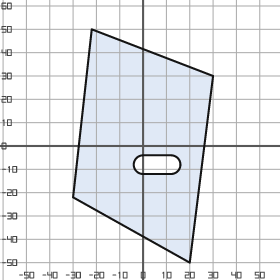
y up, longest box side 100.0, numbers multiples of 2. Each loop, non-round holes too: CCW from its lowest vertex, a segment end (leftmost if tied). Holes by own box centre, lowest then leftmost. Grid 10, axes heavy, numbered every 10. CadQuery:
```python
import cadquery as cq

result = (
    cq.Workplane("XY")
    .moveTo(20.0, -50.0)
    .lineTo(30.0, 30.0)
    .lineTo(-22.0, 50.0)
    .lineTo(-30.0, -22.0)
    .close()
    .moveTo(0.0, -12.0)
    .lineTo(12.0, -12.0)
    .threePointArc((16.0, -8.0), (12.0, -4.0))
    .lineTo(0.0, -4.0)
    .threePointArc((-4.0, -8.0), (0.0, -12.0))
    .close()
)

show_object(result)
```